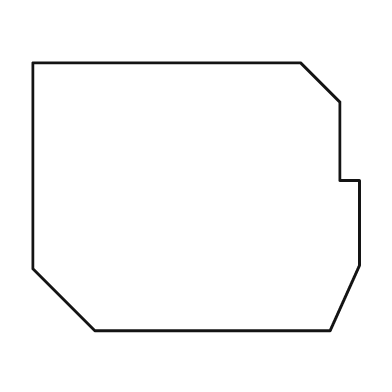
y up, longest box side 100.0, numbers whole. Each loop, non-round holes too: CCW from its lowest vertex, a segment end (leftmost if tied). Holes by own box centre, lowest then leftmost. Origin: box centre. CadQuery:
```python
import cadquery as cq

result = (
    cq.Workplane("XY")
    .moveTo(-31.0, -41.0)
    .lineTo(41.0, -41.0)
    .lineTo(50.0, -21.0)
    .lineTo(50.0, 5.0)
    .lineTo(44.0, 5.0)
    .lineTo(44.0, 29.0)
    .lineTo(32.0, 41.0)
    .lineTo(-50.0, 41.0)
    .lineTo(-50.0, -22.0)
    .close()
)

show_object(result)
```